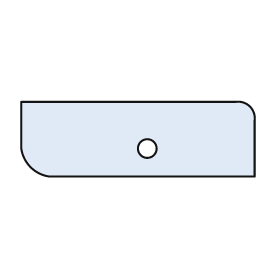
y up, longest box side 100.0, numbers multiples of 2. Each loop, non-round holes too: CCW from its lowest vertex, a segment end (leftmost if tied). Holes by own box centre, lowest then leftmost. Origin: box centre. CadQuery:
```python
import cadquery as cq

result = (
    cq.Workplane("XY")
    .moveTo(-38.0, -16.0)
    .lineTo(50.0, -16.0)
    .lineTo(50.0, 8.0)
    .threePointArc((48.0, 14.0), (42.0, 16.0))
    .lineTo(-50.0, 16.0)
    .lineTo(-50.0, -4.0)
    .threePointArc((-46.0, -12.0), (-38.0, -16.0))
    .close()
    .moveTo(4.0, -4.0)
    .circle(4.0)
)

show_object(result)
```